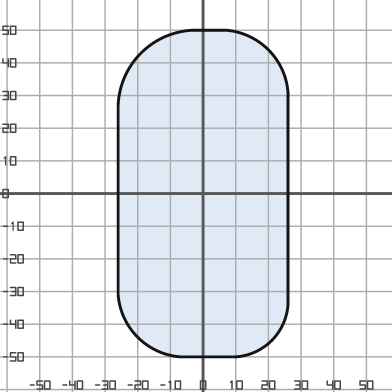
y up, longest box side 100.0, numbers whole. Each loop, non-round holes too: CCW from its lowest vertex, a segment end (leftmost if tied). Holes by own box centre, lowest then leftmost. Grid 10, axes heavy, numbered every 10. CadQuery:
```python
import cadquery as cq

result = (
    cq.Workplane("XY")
    .moveTo(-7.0, -50.0)
    .lineTo(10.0, -50.0)
    .threePointArc((21.0, -45.0), (26.0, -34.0))
    .lineTo(26.0, 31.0)
    .threePointArc((20.0, 44.0), (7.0, 50.0))
    .lineTo(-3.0, 50.0)
    .threePointArc((-19.0, 43.0), (-26.0, 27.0))
    .lineTo(-26.0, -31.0)
    .threePointArc((-20.0, -44.0), (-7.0, -50.0))
    .close()
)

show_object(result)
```